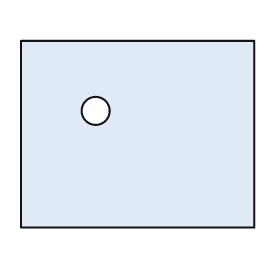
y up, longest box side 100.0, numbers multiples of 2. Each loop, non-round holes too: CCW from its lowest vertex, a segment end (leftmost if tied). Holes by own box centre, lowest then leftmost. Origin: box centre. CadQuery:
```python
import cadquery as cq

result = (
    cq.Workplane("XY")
    .moveTo(-50.0, -40.0)
    .lineTo(50.0, -40.0)
    .lineTo(50.0, 40.0)
    .lineTo(-50.0, 40.0)
    .close()
    .moveTo(-18.0, 10.0)
    .circle(6.0)
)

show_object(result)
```